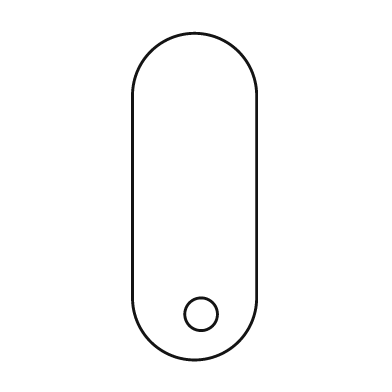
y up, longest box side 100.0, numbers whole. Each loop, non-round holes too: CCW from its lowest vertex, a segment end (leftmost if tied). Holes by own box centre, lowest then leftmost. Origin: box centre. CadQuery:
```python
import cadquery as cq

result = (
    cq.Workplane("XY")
    .moveTo(-19.0, -31.0)
    .threePointArc((0.0, -50.0), (19.0, -31.0))
    .lineTo(19.0, 31.0)
    .threePointArc((0.0, 50.0), (-19.0, 31.0))
    .close()
    .moveTo(2.0, -36.0)
    .circle(5.0)
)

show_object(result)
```